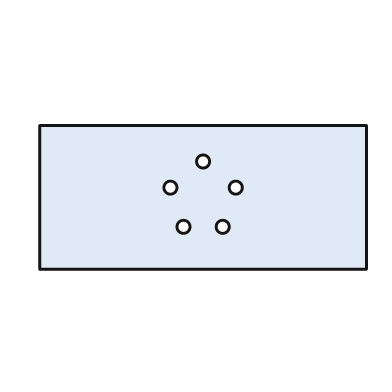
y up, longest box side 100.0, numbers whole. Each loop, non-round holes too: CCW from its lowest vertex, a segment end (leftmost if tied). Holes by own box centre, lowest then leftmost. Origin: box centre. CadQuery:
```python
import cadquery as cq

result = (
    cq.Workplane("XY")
    .moveTo(-50.0, -22.0)
    .lineTo(50.0, -22.0)
    .lineTo(50.0, 22.0)
    .lineTo(-50.0, 22.0)
    .close()
    .moveTo(-6.0, -9.0)
    .circle(2.0)
    .moveTo(6.0, -9.0)
    .circle(2.0)
    .moveTo(-10.0, 3.0)
    .circle(2.0)
    .moveTo(10.0, 3.0)
    .circle(2.0)
    .moveTo(0.0, 11.0)
    .circle(2.0)
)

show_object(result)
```